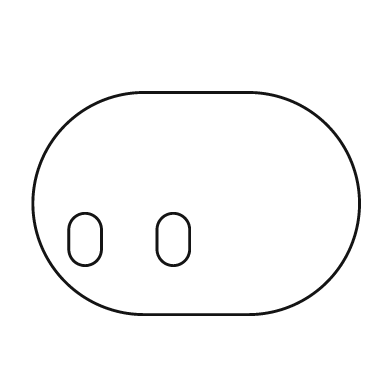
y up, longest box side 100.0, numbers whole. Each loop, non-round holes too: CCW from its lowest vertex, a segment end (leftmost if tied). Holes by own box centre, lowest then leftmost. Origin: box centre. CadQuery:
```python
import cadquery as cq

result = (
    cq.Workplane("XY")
    .moveTo(-16.0, -34.0)
    .lineTo(16.0, -34.0)
    .threePointArc((50.0, 0.0), (16.0, 34.0))
    .lineTo(-16.0, 34.0)
    .threePointArc((-50.0, 0.0), (-16.0, -34.0))
    .close()
    .moveTo(-39.0, -14.0)
    .threePointArc((-34.0, -19.0), (-29.0, -14.0))
    .lineTo(-29.0, -8.0)
    .threePointArc((-34.0, -3.0), (-39.0, -8.0))
    .close()
    .moveTo(-12.0, -14.0)
    .threePointArc((-7.0, -19.0), (-2.0, -14.0))
    .lineTo(-2.0, -8.0)
    .threePointArc((-7.0, -3.0), (-12.0, -8.0))
    .close()
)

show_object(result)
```